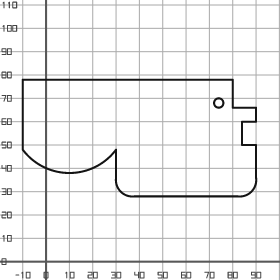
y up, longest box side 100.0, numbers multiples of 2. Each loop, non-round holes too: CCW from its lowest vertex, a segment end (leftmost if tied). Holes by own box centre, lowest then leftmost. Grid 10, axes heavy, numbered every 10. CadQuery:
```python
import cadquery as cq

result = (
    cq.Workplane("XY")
    .moveTo(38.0, 28.0)
    .lineTo(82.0, 28.0)
    .threePointArc((88.0, 30.0), (90.0, 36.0))
    .lineTo(90.0, 50.0)
    .lineTo(84.0, 50.0)
    .lineTo(84.0, 60.0)
    .lineTo(90.0, 60.0)
    .lineTo(90.0, 66.0)
    .lineTo(80.0, 66.0)
    .lineTo(80.0, 78.0)
    .lineTo(-10.0, 78.0)
    .lineTo(-10.0, 48.0)
    .threePointArc((10.0, 38.0), (30.0, 48.0))
    .lineTo(30.0, 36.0)
    .threePointArc((32.0, 30.0), (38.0, 28.0))
    .close()
    .moveTo(74.0, 68.0)
    .circle(2.0)
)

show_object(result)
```